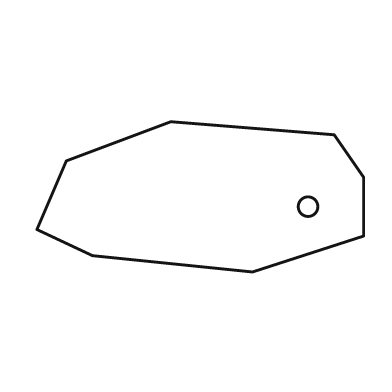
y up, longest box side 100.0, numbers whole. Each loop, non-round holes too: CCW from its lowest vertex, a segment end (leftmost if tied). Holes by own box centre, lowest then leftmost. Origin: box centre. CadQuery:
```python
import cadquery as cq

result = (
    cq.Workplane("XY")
    .moveTo(16.0, -23.0)
    .lineTo(50.0, -12.0)
    .lineTo(50.0, 6.0)
    .lineTo(41.0, 19.0)
    .lineTo(-9.0, 23.0)
    .lineTo(-41.0, 11.0)
    .lineTo(-50.0, -10.0)
    .lineTo(-33.0, -18.0)
    .close()
    .moveTo(33.0, -3.0)
    .circle(3.0)
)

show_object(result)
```